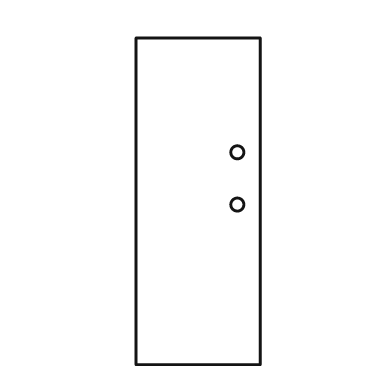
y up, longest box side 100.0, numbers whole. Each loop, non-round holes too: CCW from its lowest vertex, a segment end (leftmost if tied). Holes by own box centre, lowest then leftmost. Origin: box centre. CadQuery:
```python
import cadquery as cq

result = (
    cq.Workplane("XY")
    .moveTo(-19.0, -50.0)
    .lineTo(19.0, -50.0)
    .lineTo(19.0, 50.0)
    .lineTo(-19.0, 50.0)
    .close()
    .moveTo(12.0, -1.0)
    .circle(2.0)
    .moveTo(12.0, 15.0)
    .circle(2.0)
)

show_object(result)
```